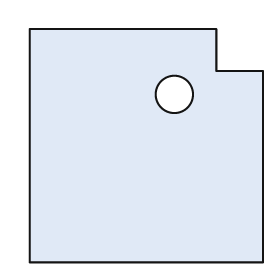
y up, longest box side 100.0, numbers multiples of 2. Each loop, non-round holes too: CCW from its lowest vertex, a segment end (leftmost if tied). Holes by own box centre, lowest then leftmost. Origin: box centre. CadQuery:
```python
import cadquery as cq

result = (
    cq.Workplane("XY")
    .moveTo(-50.0, -50.0)
    .lineTo(50.0, -50.0)
    .lineTo(50.0, 32.0)
    .lineTo(30.0, 32.0)
    .lineTo(30.0, 50.0)
    .lineTo(-50.0, 50.0)
    .close()
    .moveTo(12.0, 22.0)
    .circle(8.0)
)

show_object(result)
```